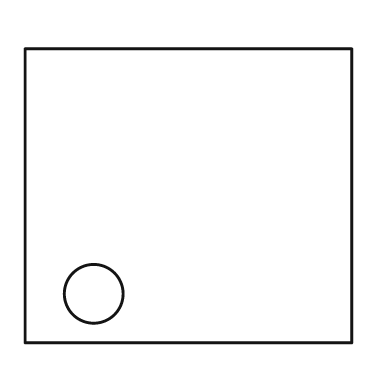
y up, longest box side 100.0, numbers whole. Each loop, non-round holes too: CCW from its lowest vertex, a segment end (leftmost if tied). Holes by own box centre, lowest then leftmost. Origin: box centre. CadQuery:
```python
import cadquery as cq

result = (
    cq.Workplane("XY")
    .moveTo(-50.0, -45.0)
    .lineTo(50.0, -45.0)
    .lineTo(50.0, 45.0)
    .lineTo(-50.0, 45.0)
    .close()
    .moveTo(-29.0, -30.0)
    .circle(9.0)
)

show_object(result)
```